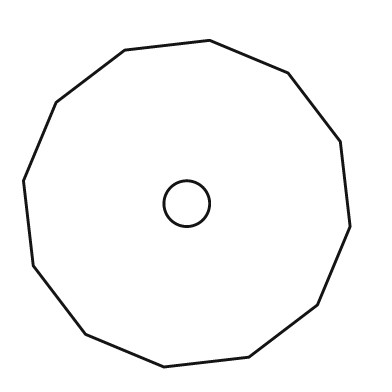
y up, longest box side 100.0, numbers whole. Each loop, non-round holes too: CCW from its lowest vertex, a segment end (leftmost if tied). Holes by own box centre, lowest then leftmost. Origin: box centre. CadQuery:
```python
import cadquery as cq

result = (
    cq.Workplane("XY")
    .moveTo(-7.0, -50.0)
    .lineTo(19.0, -47.0)
    .lineTo(40.0, -31.0)
    .lineTo(50.0, -7.0)
    .lineTo(47.0, 19.0)
    .lineTo(31.0, 40.0)
    .lineTo(7.0, 50.0)
    .lineTo(-19.0, 47.0)
    .lineTo(-40.0, 31.0)
    .lineTo(-50.0, 7.0)
    .lineTo(-47.0, -19.0)
    .lineTo(-31.0, -40.0)
    .close()
    .moveTo(0.0, 0.0)
    .circle(7.0)
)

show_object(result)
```